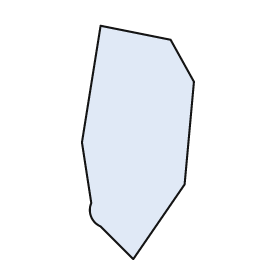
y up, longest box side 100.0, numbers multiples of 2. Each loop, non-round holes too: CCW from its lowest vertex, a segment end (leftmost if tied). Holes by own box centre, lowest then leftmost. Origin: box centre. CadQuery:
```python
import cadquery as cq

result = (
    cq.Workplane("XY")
    .moveTo(-2.0, -50.0)
    .lineTo(20.0, -18.0)
    .lineTo(24.0, 26.0)
    .lineTo(14.0, 44.0)
    .lineTo(-16.0, 50.0)
    .lineTo(-24.0, 0.0)
    .lineTo(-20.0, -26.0)
    .threePointArc((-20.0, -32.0), (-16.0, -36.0))
    .close()
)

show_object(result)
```